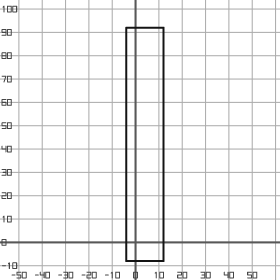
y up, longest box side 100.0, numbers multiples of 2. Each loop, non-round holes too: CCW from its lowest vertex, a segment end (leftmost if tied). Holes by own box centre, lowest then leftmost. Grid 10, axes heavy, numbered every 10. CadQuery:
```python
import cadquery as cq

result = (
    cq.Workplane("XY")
    .moveTo(-4.0, -8.0)
    .lineTo(12.0, -8.0)
    .lineTo(12.0, 92.0)
    .lineTo(-4.0, 92.0)
    .close()
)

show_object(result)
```